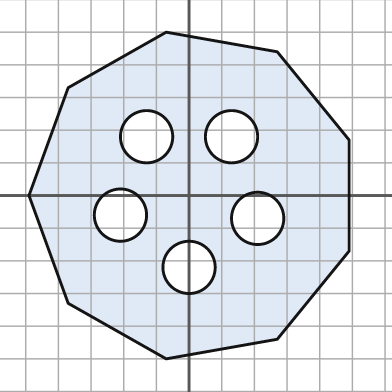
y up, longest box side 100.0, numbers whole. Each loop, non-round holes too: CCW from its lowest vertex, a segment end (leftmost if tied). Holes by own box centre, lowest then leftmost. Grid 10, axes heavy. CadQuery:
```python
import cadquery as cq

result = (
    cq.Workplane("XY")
    .moveTo(-7.0, -50.0)
    .lineTo(27.0, -44.0)
    .lineTo(49.0, -17.0)
    .lineTo(49.0, 17.0)
    .lineTo(27.0, 44.0)
    .lineTo(-7.0, 50.0)
    .lineTo(-37.0, 33.0)
    .lineTo(-49.0, 0.0)
    .lineTo(-37.0, -33.0)
    .close()
    .moveTo(0.0, -22.0)
    .circle(8.0)
    .moveTo(21.0, -7.0)
    .circle(8.0)
    .moveTo(-21.0, -6.0)
    .circle(8.0)
    .moveTo(-13.0, 18.0)
    .circle(8.0)
    .moveTo(13.0, 18.0)
    .circle(8.0)
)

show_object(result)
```